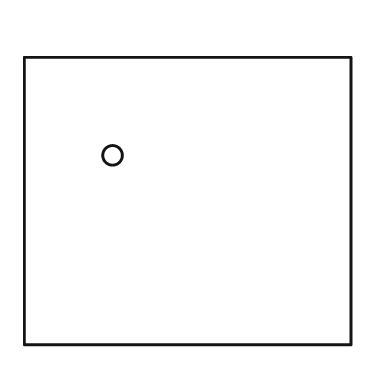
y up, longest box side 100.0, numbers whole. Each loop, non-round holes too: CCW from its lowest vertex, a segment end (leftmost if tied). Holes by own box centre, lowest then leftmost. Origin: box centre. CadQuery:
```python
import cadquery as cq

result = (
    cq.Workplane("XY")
    .moveTo(-50.0, -44.0)
    .lineTo(50.0, -44.0)
    .lineTo(50.0, 44.0)
    .lineTo(-50.0, 44.0)
    .close()
    .moveTo(-23.0, 14.0)
    .circle(3.0)
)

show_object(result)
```